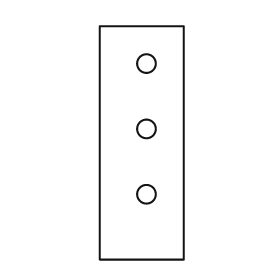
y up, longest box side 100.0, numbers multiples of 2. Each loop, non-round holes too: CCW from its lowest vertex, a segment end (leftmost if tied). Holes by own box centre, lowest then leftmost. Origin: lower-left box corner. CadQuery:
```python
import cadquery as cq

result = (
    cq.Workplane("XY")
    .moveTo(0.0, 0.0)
    .lineTo(36.0, 0.0)
    .lineTo(36.0, 100.0)
    .lineTo(0.0, 100.0)
    .close()
    .moveTo(20.0, 28.0)
    .circle(4.0)
    .moveTo(20.0, 56.0)
    .circle(4.0)
    .moveTo(20.0, 84.0)
    .circle(4.0)
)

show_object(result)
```